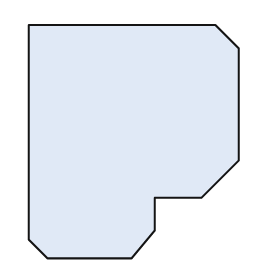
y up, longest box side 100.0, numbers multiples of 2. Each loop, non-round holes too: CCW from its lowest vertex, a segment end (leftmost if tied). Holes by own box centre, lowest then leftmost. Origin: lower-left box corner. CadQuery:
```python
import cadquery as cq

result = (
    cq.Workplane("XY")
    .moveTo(8.0, 0.0)
    .lineTo(44.0, 0.0)
    .lineTo(54.0, 12.0)
    .lineTo(54.0, 26.0)
    .lineTo(74.0, 26.0)
    .lineTo(90.0, 42.0)
    .lineTo(90.0, 90.0)
    .lineTo(80.0, 100.0)
    .lineTo(0.0, 100.0)
    .lineTo(0.0, 8.0)
    .close()
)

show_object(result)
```